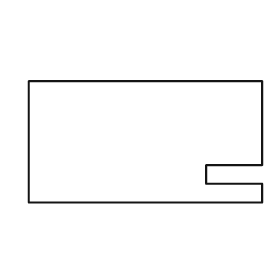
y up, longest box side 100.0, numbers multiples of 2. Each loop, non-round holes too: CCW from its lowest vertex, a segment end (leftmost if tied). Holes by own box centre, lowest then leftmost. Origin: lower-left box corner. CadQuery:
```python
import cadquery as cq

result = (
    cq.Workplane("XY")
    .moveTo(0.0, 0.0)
    .lineTo(100.0, 0.0)
    .lineTo(100.0, 8.0)
    .lineTo(76.0, 8.0)
    .lineTo(76.0, 16.0)
    .lineTo(100.0, 16.0)
    .lineTo(100.0, 52.0)
    .lineTo(0.0, 52.0)
    .close()
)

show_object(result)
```